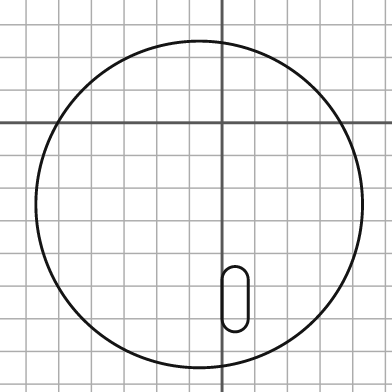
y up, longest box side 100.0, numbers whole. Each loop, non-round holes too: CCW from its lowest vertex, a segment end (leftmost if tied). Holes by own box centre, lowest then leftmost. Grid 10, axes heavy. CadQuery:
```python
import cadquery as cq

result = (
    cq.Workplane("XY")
    .moveTo(-7.0, -25.0)
    .circle(50.0)
    .moveTo(0.0, -60.0)
    .threePointArc((4.0, -64.0), (8.0, -60.0))
    .lineTo(8.0, -48.0)
    .threePointArc((4.0, -44.0), (0.0, -48.0))
    .close()
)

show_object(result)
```